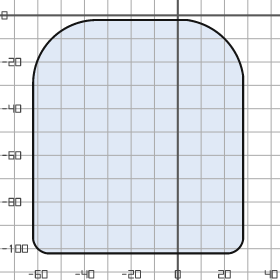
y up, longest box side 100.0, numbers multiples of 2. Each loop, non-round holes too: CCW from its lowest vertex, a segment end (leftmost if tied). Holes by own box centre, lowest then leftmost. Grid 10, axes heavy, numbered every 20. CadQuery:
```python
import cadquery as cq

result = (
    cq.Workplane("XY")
    .moveTo(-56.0, -102.0)
    .lineTo(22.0, -102.0)
    .threePointArc((26.0, -100.0), (28.0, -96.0))
    .lineTo(28.0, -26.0)
    .threePointArc((20.0, -10.0), (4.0, -2.0))
    .lineTo(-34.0, -2.0)
    .threePointArc((-54.0, -10.0), (-62.0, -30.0))
    .lineTo(-62.0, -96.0)
    .threePointArc((-60.0, -100.0), (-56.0, -102.0))
    .close()
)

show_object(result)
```